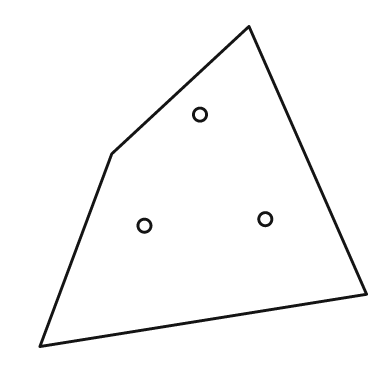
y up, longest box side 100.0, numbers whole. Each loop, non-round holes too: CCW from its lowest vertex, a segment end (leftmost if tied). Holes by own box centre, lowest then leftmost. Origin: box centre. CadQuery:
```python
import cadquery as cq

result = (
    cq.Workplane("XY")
    .moveTo(-50.0, -49.0)
    .lineTo(50.0, -33.0)
    .lineTo(14.0, 49.0)
    .lineTo(-28.0, 10.0)
    .close()
    .moveTo(-18.0, -12.0)
    .circle(2.0)
    .moveTo(19.0, -10.0)
    .circle(2.0)
    .moveTo(-1.0, 22.0)
    .circle(2.0)
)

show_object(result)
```